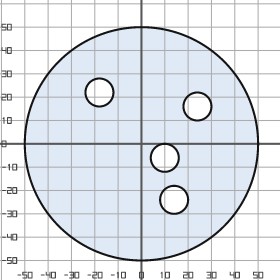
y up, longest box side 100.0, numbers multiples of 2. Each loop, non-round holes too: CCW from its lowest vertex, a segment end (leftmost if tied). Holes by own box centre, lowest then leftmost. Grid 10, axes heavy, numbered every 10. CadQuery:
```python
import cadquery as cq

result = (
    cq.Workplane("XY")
    .moveTo(0.0, 0.0)
    .circle(50.0)
    .moveTo(14.0, -24.0)
    .circle(6.0)
    .moveTo(10.0, -6.0)
    .circle(6.0)
    .moveTo(24.0, 16.0)
    .circle(6.0)
    .moveTo(-18.0, 22.0)
    .circle(6.0)
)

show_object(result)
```